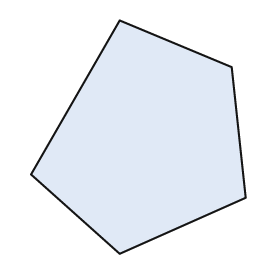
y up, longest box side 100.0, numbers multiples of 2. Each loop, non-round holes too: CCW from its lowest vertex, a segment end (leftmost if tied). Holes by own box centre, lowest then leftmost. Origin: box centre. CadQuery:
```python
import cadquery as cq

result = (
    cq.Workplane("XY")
    .moveTo(-8.0, -50.0)
    .lineTo(46.0, -26.0)
    .lineTo(40.0, 30.0)
    .lineTo(-8.0, 50.0)
    .lineTo(-46.0, -16.0)
    .close()
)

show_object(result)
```